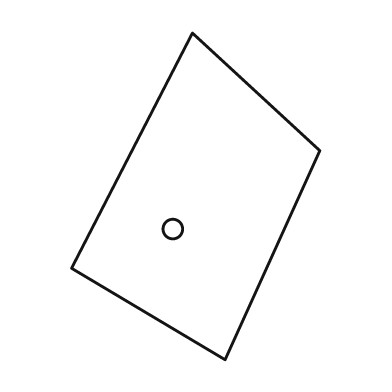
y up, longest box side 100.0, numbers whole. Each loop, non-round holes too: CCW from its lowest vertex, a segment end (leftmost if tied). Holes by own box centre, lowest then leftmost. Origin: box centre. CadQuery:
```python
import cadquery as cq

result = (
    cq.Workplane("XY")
    .moveTo(9.0, -50.0)
    .lineTo(38.0, 14.0)
    .lineTo(-1.0, 50.0)
    .lineTo(-38.0, -22.0)
    .close()
    .moveTo(-7.0, -10.0)
    .circle(3.0)
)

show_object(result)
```